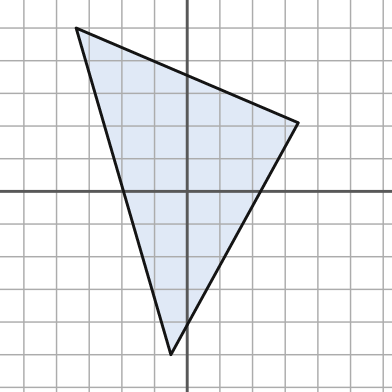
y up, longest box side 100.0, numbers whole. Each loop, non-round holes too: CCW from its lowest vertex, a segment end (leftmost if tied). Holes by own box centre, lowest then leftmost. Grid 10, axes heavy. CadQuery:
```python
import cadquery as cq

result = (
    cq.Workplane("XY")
    .moveTo(-5.0, -50.0)
    .lineTo(34.0, 21.0)
    .lineTo(-34.0, 50.0)
    .close()
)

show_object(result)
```